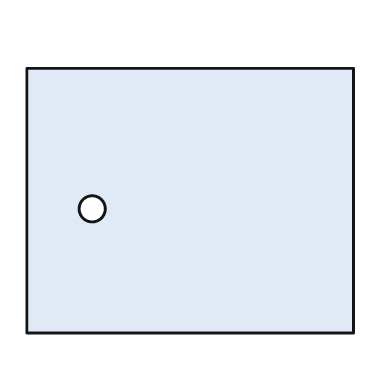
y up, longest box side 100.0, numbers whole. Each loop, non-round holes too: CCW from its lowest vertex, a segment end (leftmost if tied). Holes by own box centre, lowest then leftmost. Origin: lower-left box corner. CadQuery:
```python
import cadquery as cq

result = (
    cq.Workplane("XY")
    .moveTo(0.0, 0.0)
    .lineTo(100.0, 0.0)
    .lineTo(100.0, 81.0)
    .lineTo(0.0, 81.0)
    .close()
    .moveTo(20.0, 38.0)
    .circle(4.0)
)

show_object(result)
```